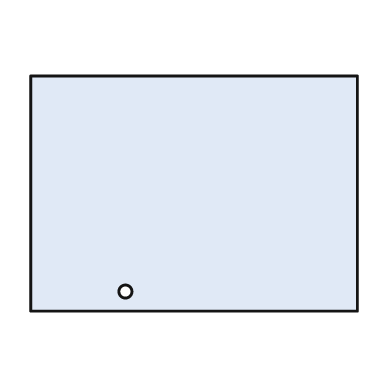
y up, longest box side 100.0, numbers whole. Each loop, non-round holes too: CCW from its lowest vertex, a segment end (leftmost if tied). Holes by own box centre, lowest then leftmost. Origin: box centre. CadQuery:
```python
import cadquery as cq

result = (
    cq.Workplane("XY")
    .moveTo(-50.0, -36.0)
    .lineTo(50.0, -36.0)
    .lineTo(50.0, 36.0)
    .lineTo(-50.0, 36.0)
    .close()
    .moveTo(-21.0, -30.0)
    .circle(2.0)
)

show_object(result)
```